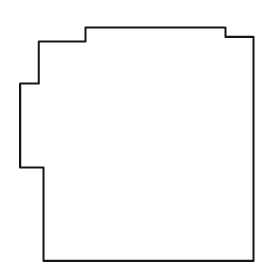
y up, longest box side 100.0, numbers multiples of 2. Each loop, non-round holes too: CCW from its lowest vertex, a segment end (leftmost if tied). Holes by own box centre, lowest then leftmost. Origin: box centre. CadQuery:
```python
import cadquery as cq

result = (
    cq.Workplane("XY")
    .moveTo(-40.0, -50.0)
    .lineTo(50.0, -50.0)
    .lineTo(50.0, 46.0)
    .lineTo(38.0, 46.0)
    .lineTo(38.0, 50.0)
    .lineTo(-22.0, 50.0)
    .lineTo(-22.0, 44.0)
    .lineTo(-42.0, 44.0)
    .lineTo(-42.0, 26.0)
    .lineTo(-50.0, 26.0)
    .lineTo(-50.0, -10.0)
    .lineTo(-40.0, -10.0)
    .close()
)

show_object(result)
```